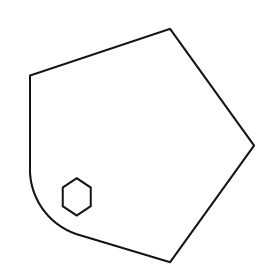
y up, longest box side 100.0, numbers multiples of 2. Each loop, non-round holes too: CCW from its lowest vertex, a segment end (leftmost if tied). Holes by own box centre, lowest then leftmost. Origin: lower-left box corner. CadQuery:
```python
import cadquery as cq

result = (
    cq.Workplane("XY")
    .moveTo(60.0, 0.0)
    .lineTo(96.0, 50.0)
    .lineTo(60.0, 100.0)
    .lineTo(0.0, 80.0)
    .lineTo(0.0, 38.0)
    .threePointArc((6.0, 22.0), (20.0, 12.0))
    .close()
    .moveTo(20.0, 20.0)
    .lineTo(26.0, 24.0)
    .lineTo(26.0, 32.0)
    .lineTo(20.0, 36.0)
    .lineTo(14.0, 32.0)
    .lineTo(14.0, 24.0)
    .close()
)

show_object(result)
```